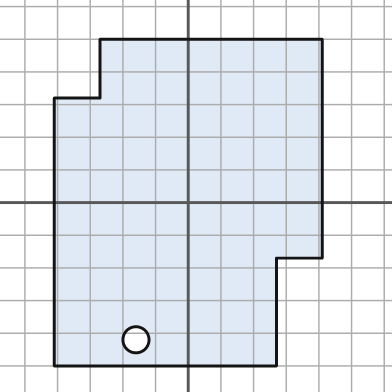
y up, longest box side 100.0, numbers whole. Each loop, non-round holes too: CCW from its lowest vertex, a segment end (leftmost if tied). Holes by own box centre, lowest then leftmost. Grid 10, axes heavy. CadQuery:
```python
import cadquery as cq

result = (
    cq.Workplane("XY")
    .moveTo(-41.0, -50.0)
    .lineTo(27.0, -50.0)
    .lineTo(27.0, -17.0)
    .lineTo(41.0, -17.0)
    .lineTo(41.0, 50.0)
    .lineTo(-27.0, 50.0)
    .lineTo(-27.0, 32.0)
    .lineTo(-41.0, 32.0)
    .close()
    .moveTo(-16.0, -42.0)
    .circle(4.0)
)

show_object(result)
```